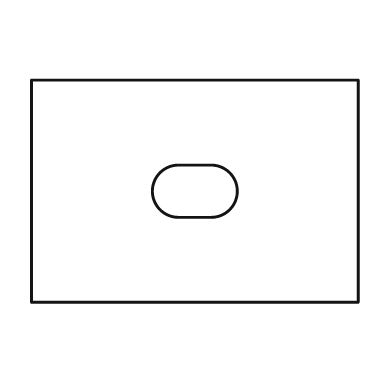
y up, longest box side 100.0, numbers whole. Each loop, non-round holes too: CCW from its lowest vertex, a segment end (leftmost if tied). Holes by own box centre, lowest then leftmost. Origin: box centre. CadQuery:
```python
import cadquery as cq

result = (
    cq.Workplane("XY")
    .moveTo(-50.0, -34.0)
    .lineTo(50.0, -34.0)
    .lineTo(50.0, 34.0)
    .lineTo(-50.0, 34.0)
    .close()
    .moveTo(-5.0, -8.0)
    .lineTo(5.0, -8.0)
    .threePointArc((13.0, 0.0), (5.0, 8.0))
    .lineTo(-5.0, 8.0)
    .threePointArc((-13.0, 0.0), (-5.0, -8.0))
    .close()
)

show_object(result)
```